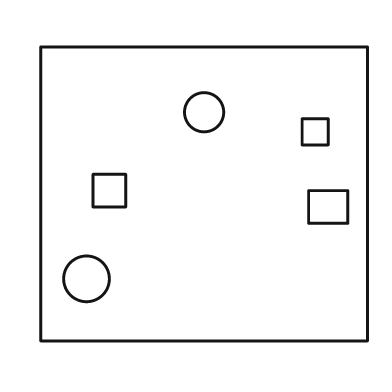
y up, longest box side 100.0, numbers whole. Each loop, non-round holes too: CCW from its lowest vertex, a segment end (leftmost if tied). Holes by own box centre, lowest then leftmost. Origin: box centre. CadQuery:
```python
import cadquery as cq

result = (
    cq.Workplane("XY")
    .moveTo(-50.0, -45.0)
    .lineTo(50.0, -45.0)
    .lineTo(50.0, 45.0)
    .lineTo(-50.0, 45.0)
    .close()
    .moveTo(-36.0, -26.0)
    .circle(7.0)
    .moveTo(32.0, -9.0)
    .lineTo(44.0, -9.0)
    .lineTo(44.0, 1.0)
    .lineTo(32.0, 1.0)
    .close()
    .moveTo(-34.0, -4.0)
    .lineTo(-24.0, -4.0)
    .lineTo(-24.0, 6.0)
    .lineTo(-34.0, 6.0)
    .close()
    .moveTo(30.0, 15.0)
    .lineTo(38.0, 15.0)
    .lineTo(38.0, 23.0)
    .lineTo(30.0, 23.0)
    .close()
    .moveTo(0.0, 25.0)
    .circle(6.0)
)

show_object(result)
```